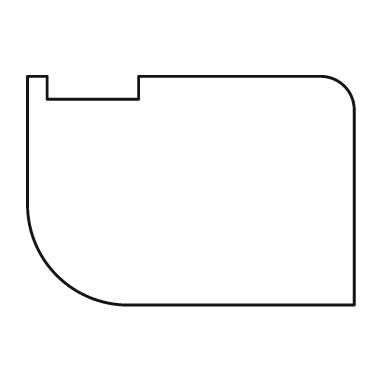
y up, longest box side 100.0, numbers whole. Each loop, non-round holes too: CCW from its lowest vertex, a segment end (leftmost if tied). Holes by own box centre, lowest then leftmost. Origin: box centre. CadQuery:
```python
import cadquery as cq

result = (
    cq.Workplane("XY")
    .moveTo(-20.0, -35.0)
    .lineTo(50.0, -35.0)
    .lineTo(50.0, 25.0)
    .threePointArc((47.0, 32.0), (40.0, 35.0))
    .lineTo(-16.0, 35.0)
    .lineTo(-16.0, 28.0)
    .lineTo(-44.0, 28.0)
    .lineTo(-44.0, 35.0)
    .lineTo(-50.0, 35.0)
    .lineTo(-50.0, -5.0)
    .threePointArc((-41.0, -26.0), (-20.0, -35.0))
    .close()
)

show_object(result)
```